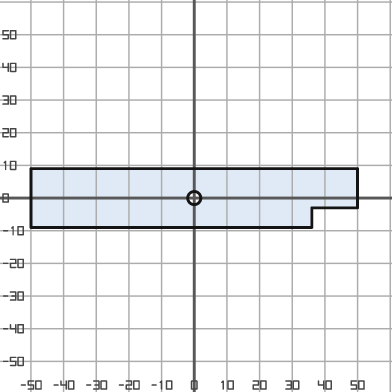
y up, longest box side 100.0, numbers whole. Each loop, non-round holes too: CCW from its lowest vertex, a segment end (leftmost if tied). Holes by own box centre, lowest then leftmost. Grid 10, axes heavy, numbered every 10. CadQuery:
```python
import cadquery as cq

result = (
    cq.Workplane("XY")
    .moveTo(-50.0, -9.0)
    .lineTo(36.0, -9.0)
    .lineTo(36.0, -3.0)
    .lineTo(50.0, -3.0)
    .lineTo(50.0, 9.0)
    .lineTo(-50.0, 9.0)
    .close()
    .moveTo(0.0, 0.0)
    .circle(2.0)
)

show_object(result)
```